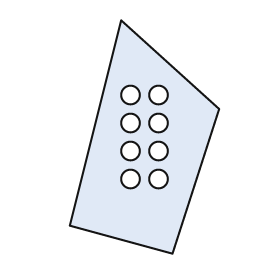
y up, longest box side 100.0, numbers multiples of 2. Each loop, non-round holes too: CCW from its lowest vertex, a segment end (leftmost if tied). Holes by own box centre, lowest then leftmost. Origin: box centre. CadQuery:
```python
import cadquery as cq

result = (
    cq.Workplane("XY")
    .moveTo(12.0, -50.0)
    .lineTo(32.0, 12.0)
    .lineTo(-10.0, 50.0)
    .lineTo(-32.0, -38.0)
    .close()
    .moveTo(-6.0, -18.0)
    .circle(4.0)
    .moveTo(6.0, -18.0)
    .circle(4.0)
    .moveTo(-6.0, -6.0)
    .circle(4.0)
    .moveTo(6.0, -6.0)
    .circle(4.0)
    .moveTo(-6.0, 6.0)
    .circle(4.0)
    .moveTo(6.0, 6.0)
    .circle(4.0)
    .moveTo(-6.0, 18.0)
    .circle(4.0)
    .moveTo(6.0, 18.0)
    .circle(4.0)
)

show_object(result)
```